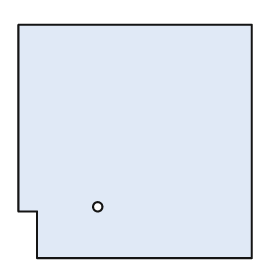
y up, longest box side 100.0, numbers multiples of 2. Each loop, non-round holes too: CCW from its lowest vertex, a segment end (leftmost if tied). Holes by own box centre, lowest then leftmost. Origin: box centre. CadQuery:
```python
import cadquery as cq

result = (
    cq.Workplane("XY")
    .moveTo(-42.0, -50.0)
    .lineTo(50.0, -50.0)
    .lineTo(50.0, 50.0)
    .lineTo(-50.0, 50.0)
    .lineTo(-50.0, -30.0)
    .lineTo(-42.0, -30.0)
    .close()
    .moveTo(-16.0, -28.0)
    .circle(2.0)
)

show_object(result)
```